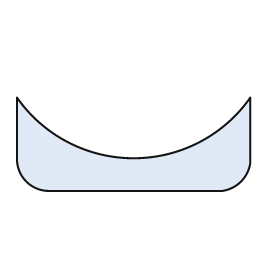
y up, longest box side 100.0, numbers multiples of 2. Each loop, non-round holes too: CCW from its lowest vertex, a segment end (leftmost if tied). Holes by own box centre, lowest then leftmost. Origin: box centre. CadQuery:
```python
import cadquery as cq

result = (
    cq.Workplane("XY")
    .moveTo(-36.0, -20.0)
    .lineTo(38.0, -20.0)
    .threePointArc((46.0, -16.0), (50.0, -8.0))
    .lineTo(50.0, 20.0)
    .threePointArc((0.0, -6.0), (-50.0, 20.0))
    .lineTo(-50.0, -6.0)
    .threePointArc((-46.0, -16.0), (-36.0, -20.0))
    .close()
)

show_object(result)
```